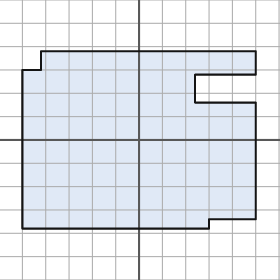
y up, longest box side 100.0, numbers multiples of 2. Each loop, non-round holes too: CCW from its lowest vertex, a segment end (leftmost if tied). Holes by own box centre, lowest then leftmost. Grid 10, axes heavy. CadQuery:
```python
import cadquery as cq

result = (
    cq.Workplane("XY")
    .moveTo(-50.0, -38.0)
    .lineTo(30.0, -38.0)
    .lineTo(30.0, -34.0)
    .lineTo(50.0, -34.0)
    .lineTo(50.0, 16.0)
    .lineTo(24.0, 16.0)
    .lineTo(24.0, 28.0)
    .lineTo(50.0, 28.0)
    .lineTo(50.0, 38.0)
    .lineTo(-42.0, 38.0)
    .lineTo(-42.0, 30.0)
    .lineTo(-50.0, 30.0)
    .close()
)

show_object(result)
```